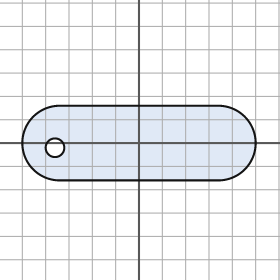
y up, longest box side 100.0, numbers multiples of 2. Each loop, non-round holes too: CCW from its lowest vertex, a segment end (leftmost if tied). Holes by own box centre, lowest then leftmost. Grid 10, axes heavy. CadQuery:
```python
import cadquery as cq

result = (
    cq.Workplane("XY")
    .moveTo(-34.0, -16.0)
    .lineTo(34.0, -16.0)
    .threePointArc((50.0, 0.0), (34.0, 16.0))
    .lineTo(-34.0, 16.0)
    .threePointArc((-50.0, 0.0), (-34.0, -16.0))
    .close()
    .moveTo(-36.0, -2.0)
    .circle(4.0)
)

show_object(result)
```